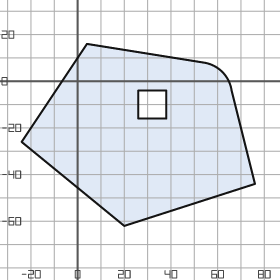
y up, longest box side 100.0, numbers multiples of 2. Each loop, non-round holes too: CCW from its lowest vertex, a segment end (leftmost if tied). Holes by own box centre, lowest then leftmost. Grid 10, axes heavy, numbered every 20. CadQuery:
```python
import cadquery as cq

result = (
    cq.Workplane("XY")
    .moveTo(20.0, -62.0)
    .lineTo(76.0, -44.0)
    .lineTo(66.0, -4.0)
    .threePointArc((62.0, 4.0), (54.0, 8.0))
    .lineTo(4.0, 16.0)
    .lineTo(-24.0, -26.0)
    .close()
    .moveTo(26.0, -16.0)
    .lineTo(38.0, -16.0)
    .lineTo(38.0, -4.0)
    .lineTo(26.0, -4.0)
    .close()
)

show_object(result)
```